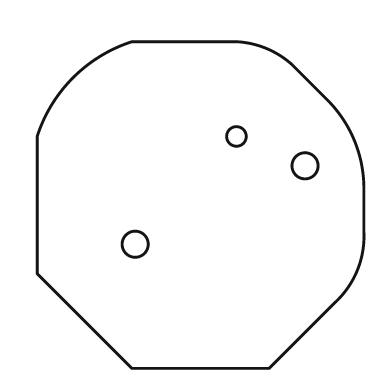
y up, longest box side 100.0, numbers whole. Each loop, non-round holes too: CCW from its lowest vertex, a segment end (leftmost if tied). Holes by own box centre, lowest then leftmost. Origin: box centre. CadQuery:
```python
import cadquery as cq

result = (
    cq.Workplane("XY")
    .moveTo(-21.0, -50.0)
    .lineTo(21.0, -50.0)
    .lineTo(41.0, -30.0)
    .threePointArc((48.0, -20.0), (50.0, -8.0))
    .lineTo(50.0, 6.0)
    .threePointArc((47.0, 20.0), (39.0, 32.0))
    .lineTo(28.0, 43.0)
    .threePointArc((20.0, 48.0), (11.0, 50.0))
    .lineTo(-21.0, 50.0)
    .threePointArc((-39.0, 39.0), (-50.0, 21.0))
    .lineTo(-50.0, -21.0)
    .close()
    .moveTo(-20.0, -12.0)
    .circle(4.0)
    .moveTo(32.0, 12.0)
    .circle(4.0)
    .moveTo(11.0, 21.0)
    .circle(3.0)
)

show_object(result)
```